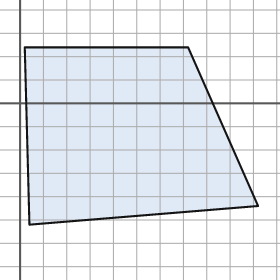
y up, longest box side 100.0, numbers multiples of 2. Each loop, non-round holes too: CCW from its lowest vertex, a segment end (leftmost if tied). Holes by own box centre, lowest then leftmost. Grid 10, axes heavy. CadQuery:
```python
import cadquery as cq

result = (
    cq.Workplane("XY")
    .moveTo(4.0, -52.0)
    .lineTo(102.0, -44.0)
    .lineTo(72.0, 24.0)
    .lineTo(2.0, 24.0)
    .close()
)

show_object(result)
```